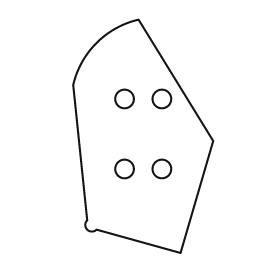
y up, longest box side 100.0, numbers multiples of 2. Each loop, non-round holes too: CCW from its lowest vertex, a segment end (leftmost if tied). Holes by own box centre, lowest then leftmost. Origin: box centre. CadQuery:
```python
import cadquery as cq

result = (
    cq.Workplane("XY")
    .moveTo(16.0, -50.0)
    .lineTo(30.0, -2.0)
    .lineTo(-2.0, 50.0)
    .threePointArc((-20.0, 40.0), (-30.0, 22.0))
    .lineTo(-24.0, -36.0)
    .threePointArc((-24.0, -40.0), (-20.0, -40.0))
    .close()
    .moveTo(-8.0, -14.0)
    .circle(4.0)
    .moveTo(8.0, -14.0)
    .circle(4.0)
    .moveTo(-8.0, 16.0)
    .circle(4.0)
    .moveTo(8.0, 16.0)
    .circle(4.0)
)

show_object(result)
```